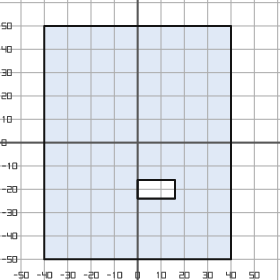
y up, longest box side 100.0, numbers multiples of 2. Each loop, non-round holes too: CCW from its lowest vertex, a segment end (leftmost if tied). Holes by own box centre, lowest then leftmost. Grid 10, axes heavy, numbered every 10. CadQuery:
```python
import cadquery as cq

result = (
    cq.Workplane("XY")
    .moveTo(-40.0, -50.0)
    .lineTo(40.0, -50.0)
    .lineTo(40.0, 50.0)
    .lineTo(-40.0, 50.0)
    .close()
    .moveTo(0.0, -24.0)
    .lineTo(16.0, -24.0)
    .lineTo(16.0, -16.0)
    .lineTo(0.0, -16.0)
    .close()
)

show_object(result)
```